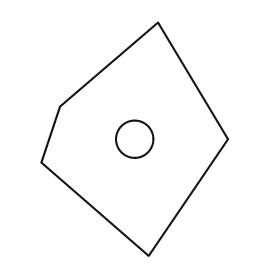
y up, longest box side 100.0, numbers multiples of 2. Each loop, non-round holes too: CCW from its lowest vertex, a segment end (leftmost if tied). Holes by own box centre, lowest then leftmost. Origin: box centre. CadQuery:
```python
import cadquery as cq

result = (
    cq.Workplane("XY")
    .moveTo(6.0, -50.0)
    .lineTo(40.0, 0.0)
    .lineTo(10.0, 50.0)
    .lineTo(-32.0, 14.0)
    .lineTo(-40.0, -10.0)
    .close()
    .moveTo(0.0, 0.0)
    .circle(8.0)
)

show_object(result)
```